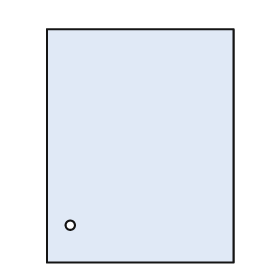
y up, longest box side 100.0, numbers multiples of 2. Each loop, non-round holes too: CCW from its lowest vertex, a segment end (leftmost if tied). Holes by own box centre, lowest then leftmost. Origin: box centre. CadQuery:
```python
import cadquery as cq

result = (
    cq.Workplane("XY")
    .moveTo(-40.0, -50.0)
    .lineTo(40.0, -50.0)
    .lineTo(40.0, 50.0)
    .lineTo(-40.0, 50.0)
    .close()
    .moveTo(-30.0, -34.0)
    .circle(2.0)
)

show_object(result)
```